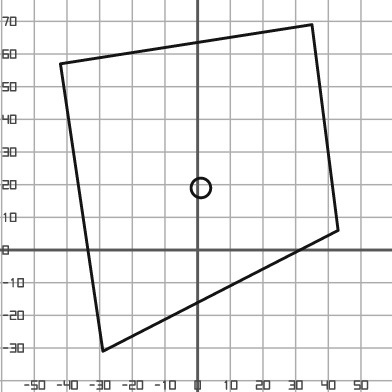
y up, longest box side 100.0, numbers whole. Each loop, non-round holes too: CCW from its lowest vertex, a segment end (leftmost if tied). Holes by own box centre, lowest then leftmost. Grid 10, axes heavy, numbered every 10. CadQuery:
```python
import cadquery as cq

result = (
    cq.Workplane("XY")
    .moveTo(-29.0, -31.0)
    .lineTo(43.0, 6.0)
    .lineTo(35.0, 69.0)
    .lineTo(-42.0, 57.0)
    .close()
    .moveTo(1.0, 19.0)
    .circle(3.0)
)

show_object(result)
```